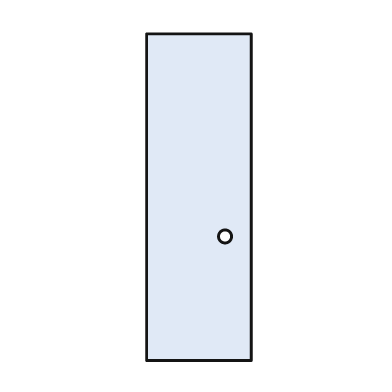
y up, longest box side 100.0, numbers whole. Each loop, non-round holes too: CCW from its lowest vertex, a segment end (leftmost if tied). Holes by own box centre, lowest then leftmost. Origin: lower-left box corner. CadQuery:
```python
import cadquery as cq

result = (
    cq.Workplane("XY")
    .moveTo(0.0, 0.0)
    .lineTo(32.0, 0.0)
    .lineTo(32.0, 100.0)
    .lineTo(0.0, 100.0)
    .close()
    .moveTo(24.0, 38.0)
    .circle(2.0)
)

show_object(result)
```